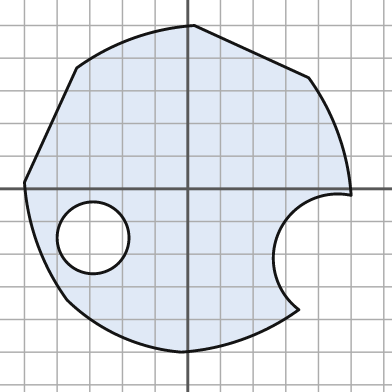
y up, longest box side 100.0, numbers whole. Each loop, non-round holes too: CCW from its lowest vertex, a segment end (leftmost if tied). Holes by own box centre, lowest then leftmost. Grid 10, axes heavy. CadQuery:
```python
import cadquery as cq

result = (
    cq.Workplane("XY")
    .moveTo(-2.0, -50.0)
    .threePointArc((17.0, -46.0), (34.0, -37.0))
    .threePointArc((28.0, -13.0), (50.0, -2.0))
    .threePointArc((46.0, 17.0), (37.0, 34.0))
    .lineTo(2.0, 50.0)
    .threePointArc((-17.0, 46.0), (-34.0, 37.0))
    .lineTo(-50.0, 2.0)
    .threePointArc((-46.0, -17.0), (-37.0, -34.0))
    .threePointArc((-21.0, -45.0), (-2.0, -50.0))
    .close()
    .moveTo(-29.0, -15.0)
    .circle(11.0)
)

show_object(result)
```